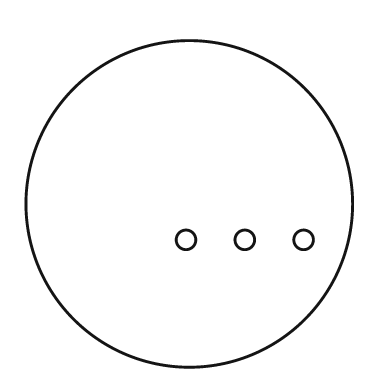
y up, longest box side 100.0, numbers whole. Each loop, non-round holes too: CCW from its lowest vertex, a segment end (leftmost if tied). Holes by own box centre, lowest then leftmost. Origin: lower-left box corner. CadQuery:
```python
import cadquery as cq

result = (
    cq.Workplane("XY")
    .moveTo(50.0, 50.0)
    .circle(50.0)
    .moveTo(49.0, 39.0)
    .circle(3.0)
    .moveTo(67.0, 39.0)
    .circle(3.0)
    .moveTo(85.0, 39.0)
    .circle(3.0)
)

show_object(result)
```